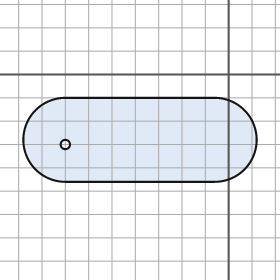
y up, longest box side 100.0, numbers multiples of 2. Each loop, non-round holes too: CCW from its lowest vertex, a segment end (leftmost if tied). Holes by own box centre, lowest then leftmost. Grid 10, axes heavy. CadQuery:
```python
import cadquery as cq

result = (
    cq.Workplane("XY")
    .moveTo(-70.0, -46.0)
    .lineTo(-6.0, -46.0)
    .threePointArc((12.0, -28.0), (-6.0, -10.0))
    .lineTo(-70.0, -10.0)
    .threePointArc((-88.0, -28.0), (-70.0, -46.0))
    .close()
    .moveTo(-70.0, -30.0)
    .circle(2.0)
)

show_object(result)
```